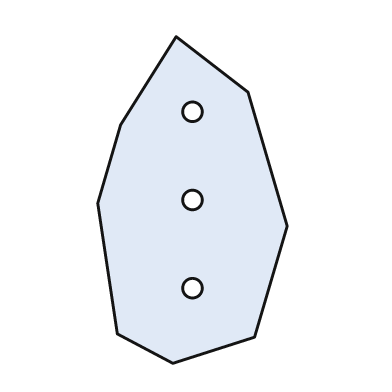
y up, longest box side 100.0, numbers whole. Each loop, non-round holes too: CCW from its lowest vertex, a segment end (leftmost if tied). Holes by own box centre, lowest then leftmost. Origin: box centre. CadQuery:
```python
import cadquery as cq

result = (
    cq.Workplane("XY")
    .moveTo(-6.0, -50.0)
    .lineTo(19.0, -42.0)
    .lineTo(29.0, -8.0)
    .lineTo(17.0, 33.0)
    .lineTo(-5.0, 50.0)
    .lineTo(-22.0, 23.0)
    .lineTo(-29.0, -1.0)
    .lineTo(-23.0, -41.0)
    .close()
    .moveTo(0.0, -27.0)
    .circle(3.0)
    .moveTo(0.0, 0.0)
    .circle(3.0)
    .moveTo(0.0, 27.0)
    .circle(3.0)
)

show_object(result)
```